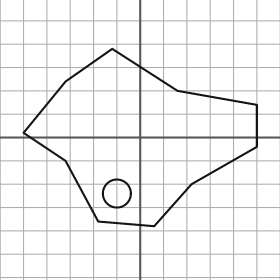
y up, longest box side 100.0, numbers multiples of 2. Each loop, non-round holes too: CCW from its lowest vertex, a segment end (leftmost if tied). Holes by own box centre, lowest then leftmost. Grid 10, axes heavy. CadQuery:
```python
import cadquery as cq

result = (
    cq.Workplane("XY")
    .moveTo(6.0, -38.0)
    .lineTo(22.0, -20.0)
    .lineTo(50.0, -4.0)
    .lineTo(50.0, 14.0)
    .lineTo(16.0, 20.0)
    .lineTo(-12.0, 38.0)
    .lineTo(-32.0, 24.0)
    .lineTo(-50.0, 2.0)
    .lineTo(-32.0, -10.0)
    .lineTo(-18.0, -36.0)
    .close()
    .moveTo(-10.0, -24.0)
    .circle(6.0)
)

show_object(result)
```